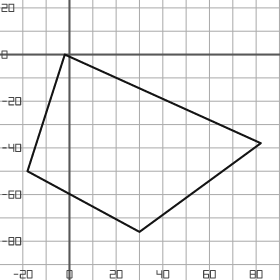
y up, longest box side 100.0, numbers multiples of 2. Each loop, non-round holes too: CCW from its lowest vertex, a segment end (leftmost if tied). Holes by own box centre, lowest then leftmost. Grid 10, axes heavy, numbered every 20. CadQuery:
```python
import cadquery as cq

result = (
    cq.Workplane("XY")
    .moveTo(30.0, -76.0)
    .lineTo(82.0, -38.0)
    .lineTo(-2.0, 0.0)
    .lineTo(-18.0, -50.0)
    .close()
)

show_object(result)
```